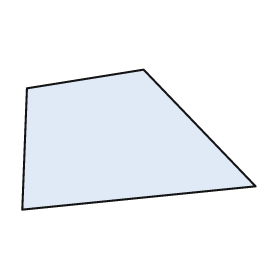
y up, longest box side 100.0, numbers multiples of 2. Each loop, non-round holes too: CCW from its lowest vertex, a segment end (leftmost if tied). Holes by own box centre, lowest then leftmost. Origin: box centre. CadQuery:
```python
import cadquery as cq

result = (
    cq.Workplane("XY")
    .moveTo(-50.0, -30.0)
    .lineTo(50.0, -20.0)
    .lineTo(2.0, 30.0)
    .lineTo(-48.0, 22.0)
    .close()
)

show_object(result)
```